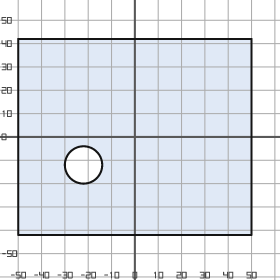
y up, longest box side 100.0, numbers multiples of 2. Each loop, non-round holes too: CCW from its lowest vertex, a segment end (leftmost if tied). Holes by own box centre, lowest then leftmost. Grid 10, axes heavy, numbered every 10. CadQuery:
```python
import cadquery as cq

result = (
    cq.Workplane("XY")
    .moveTo(-50.0, -42.0)
    .lineTo(50.0, -42.0)
    .lineTo(50.0, 42.0)
    .lineTo(-50.0, 42.0)
    .close()
    .moveTo(-22.0, -12.0)
    .circle(8.0)
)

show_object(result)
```